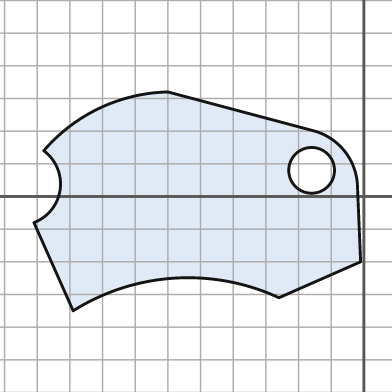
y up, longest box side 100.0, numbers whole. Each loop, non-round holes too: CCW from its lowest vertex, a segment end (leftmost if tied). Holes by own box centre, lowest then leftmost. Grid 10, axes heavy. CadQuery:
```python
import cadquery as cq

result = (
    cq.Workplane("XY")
    .moveTo(-89.0, -35.0)
    .threePointArc((-58.0, -25.0), (-26.0, -31.0))
    .lineTo(-1.0, -20.0)
    .lineTo(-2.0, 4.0)
    .threePointArc((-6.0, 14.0), (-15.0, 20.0))
    .lineTo(-60.0, 32.0)
    .threePointArc((-81.0, 27.0), (-98.0, 14.0))
    .threePointArc((-93.0, 2.0), (-101.0, -8.0))
    .close()
    .moveTo(-16.0, 8.0)
    .circle(7.0)
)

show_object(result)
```